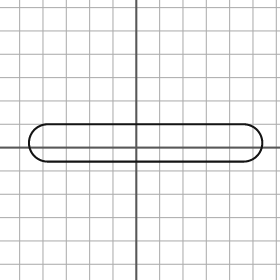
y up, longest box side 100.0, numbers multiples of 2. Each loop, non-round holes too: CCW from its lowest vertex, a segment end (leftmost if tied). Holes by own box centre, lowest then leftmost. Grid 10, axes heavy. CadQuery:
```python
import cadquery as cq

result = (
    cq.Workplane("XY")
    .moveTo(-38.0, -6.0)
    .lineTo(46.0, -6.0)
    .threePointArc((54.0, 2.0), (46.0, 10.0))
    .lineTo(-38.0, 10.0)
    .threePointArc((-46.0, 2.0), (-38.0, -6.0))
    .close()
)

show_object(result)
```